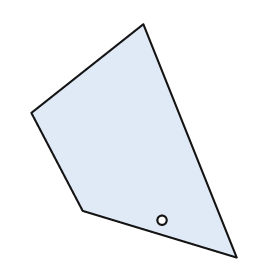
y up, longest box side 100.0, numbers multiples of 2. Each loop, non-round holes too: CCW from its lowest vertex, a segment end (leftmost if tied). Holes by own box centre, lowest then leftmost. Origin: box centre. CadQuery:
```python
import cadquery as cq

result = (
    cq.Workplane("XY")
    .moveTo(44.0, -50.0)
    .lineTo(4.0, 50.0)
    .lineTo(-44.0, 12.0)
    .lineTo(-22.0, -30.0)
    .close()
    .moveTo(12.0, -34.0)
    .circle(2.0)
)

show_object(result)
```